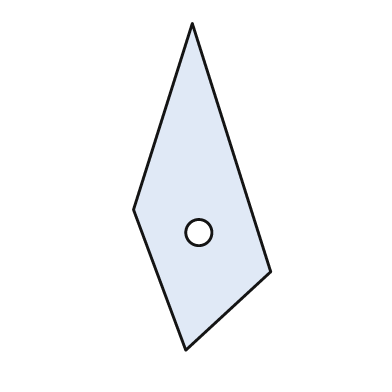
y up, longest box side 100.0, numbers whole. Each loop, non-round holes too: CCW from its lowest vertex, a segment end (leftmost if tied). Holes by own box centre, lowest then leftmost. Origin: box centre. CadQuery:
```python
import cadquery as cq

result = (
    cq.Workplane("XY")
    .moveTo(-5.0, -50.0)
    .lineTo(21.0, -26.0)
    .lineTo(-3.0, 50.0)
    .lineTo(-21.0, -7.0)
    .close()
    .moveTo(-1.0, -14.0)
    .circle(4.0)
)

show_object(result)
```